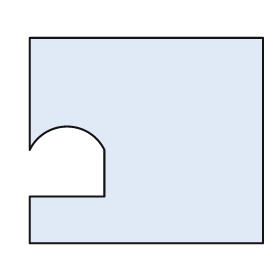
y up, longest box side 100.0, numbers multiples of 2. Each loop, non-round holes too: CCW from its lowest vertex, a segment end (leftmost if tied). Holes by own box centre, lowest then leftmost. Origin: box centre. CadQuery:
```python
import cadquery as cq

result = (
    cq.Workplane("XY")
    .moveTo(-50.0, -44.0)
    .lineTo(50.0, -44.0)
    .lineTo(50.0, 44.0)
    .lineTo(-50.0, 44.0)
    .lineTo(-50.0, -4.0)
    .threePointArc((-34.0, 6.0), (-18.0, -4.0))
    .lineTo(-18.0, -24.0)
    .lineTo(-50.0, -24.0)
    .close()
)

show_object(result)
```